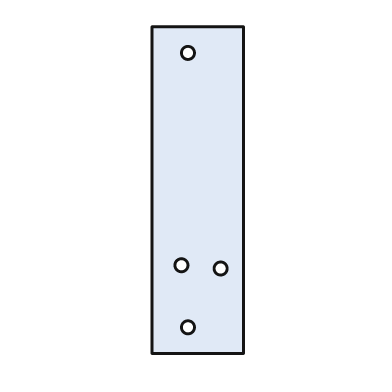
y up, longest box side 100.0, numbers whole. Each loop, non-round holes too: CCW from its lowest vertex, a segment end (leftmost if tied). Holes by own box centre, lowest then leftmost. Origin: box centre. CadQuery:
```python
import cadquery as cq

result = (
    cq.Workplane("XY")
    .moveTo(-14.0, -50.0)
    .lineTo(14.0, -50.0)
    .lineTo(14.0, 50.0)
    .lineTo(-14.0, 50.0)
    .close()
    .moveTo(-3.0, -42.0)
    .circle(2.0)
    .moveTo(7.0, -24.0)
    .circle(2.0)
    .moveTo(-5.0, -23.0)
    .circle(2.0)
    .moveTo(-3.0, 42.0)
    .circle(2.0)
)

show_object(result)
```